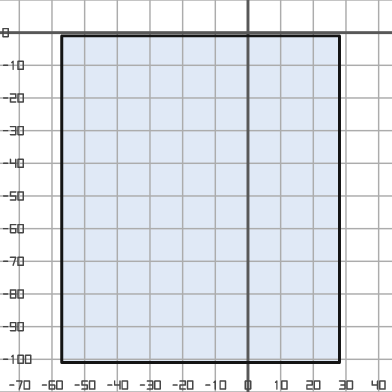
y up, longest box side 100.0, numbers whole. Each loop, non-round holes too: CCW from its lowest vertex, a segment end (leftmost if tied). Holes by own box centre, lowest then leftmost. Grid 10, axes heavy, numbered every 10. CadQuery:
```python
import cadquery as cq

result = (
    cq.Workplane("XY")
    .moveTo(-57.0, -101.0)
    .lineTo(28.0, -101.0)
    .lineTo(28.0, -1.0)
    .lineTo(-57.0, -1.0)
    .close()
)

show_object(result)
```